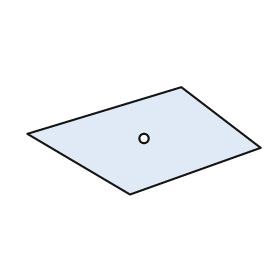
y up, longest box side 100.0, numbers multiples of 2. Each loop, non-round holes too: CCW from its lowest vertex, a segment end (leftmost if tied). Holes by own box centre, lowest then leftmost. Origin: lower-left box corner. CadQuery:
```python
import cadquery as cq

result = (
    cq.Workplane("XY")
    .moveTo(44.0, 0.0)
    .lineTo(100.0, 20.0)
    .lineTo(66.0, 46.0)
    .lineTo(0.0, 26.0)
    .close()
    .moveTo(50.0, 24.0)
    .circle(2.0)
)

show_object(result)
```